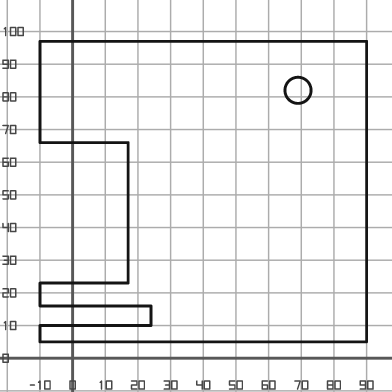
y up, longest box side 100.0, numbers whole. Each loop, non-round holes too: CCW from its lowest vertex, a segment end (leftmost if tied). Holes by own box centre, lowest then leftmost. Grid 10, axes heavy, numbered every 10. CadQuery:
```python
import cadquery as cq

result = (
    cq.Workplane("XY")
    .moveTo(-10.0, 5.0)
    .lineTo(90.0, 5.0)
    .lineTo(90.0, 97.0)
    .lineTo(-10.0, 97.0)
    .lineTo(-10.0, 66.0)
    .lineTo(17.0, 66.0)
    .lineTo(17.0, 23.0)
    .lineTo(-10.0, 23.0)
    .lineTo(-10.0, 16.0)
    .lineTo(24.0, 16.0)
    .lineTo(24.0, 10.0)
    .lineTo(-10.0, 10.0)
    .close()
    .moveTo(69.0, 82.0)
    .circle(4.0)
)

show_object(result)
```